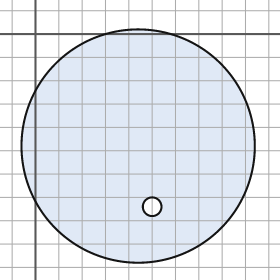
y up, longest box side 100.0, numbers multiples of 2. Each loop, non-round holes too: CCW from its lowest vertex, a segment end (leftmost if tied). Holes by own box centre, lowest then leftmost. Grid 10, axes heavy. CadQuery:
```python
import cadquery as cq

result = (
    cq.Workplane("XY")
    .moveTo(44.0, -48.0)
    .circle(50.0)
    .moveTo(50.0, -74.0)
    .circle(4.0)
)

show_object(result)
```